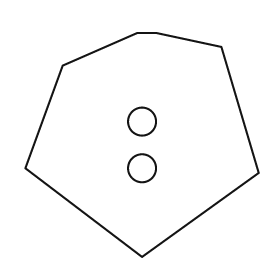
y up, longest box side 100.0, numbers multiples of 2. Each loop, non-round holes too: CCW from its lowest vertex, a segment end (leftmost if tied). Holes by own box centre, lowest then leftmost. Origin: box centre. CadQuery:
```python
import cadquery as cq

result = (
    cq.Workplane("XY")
    .moveTo(0.0, -48.0)
    .lineTo(50.0, -12.0)
    .lineTo(34.0, 42.0)
    .lineTo(6.0, 48.0)
    .lineTo(-2.0, 48.0)
    .lineTo(-34.0, 34.0)
    .lineTo(-50.0, -10.0)
    .close()
    .moveTo(0.0, -10.0)
    .circle(6.0)
    .moveTo(0.0, 10.0)
    .circle(6.0)
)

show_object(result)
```